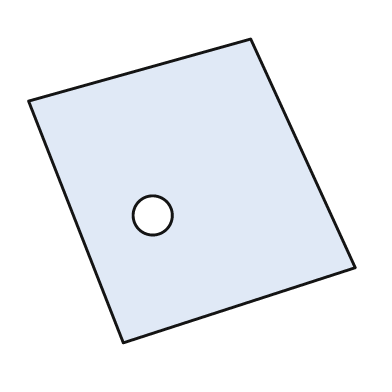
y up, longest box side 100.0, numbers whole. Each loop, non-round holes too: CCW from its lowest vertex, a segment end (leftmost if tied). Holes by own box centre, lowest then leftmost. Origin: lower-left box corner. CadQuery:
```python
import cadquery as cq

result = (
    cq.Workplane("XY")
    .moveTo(29.0, 0.0)
    .lineTo(100.0, 23.0)
    .lineTo(68.0, 93.0)
    .lineTo(0.0, 74.0)
    .close()
    .moveTo(38.0, 39.0)
    .circle(6.0)
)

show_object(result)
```